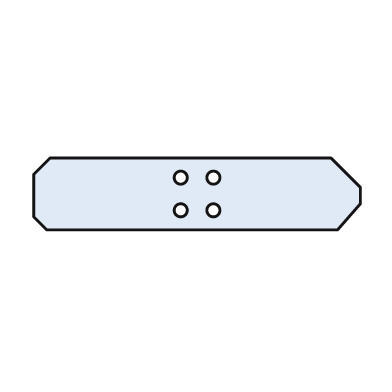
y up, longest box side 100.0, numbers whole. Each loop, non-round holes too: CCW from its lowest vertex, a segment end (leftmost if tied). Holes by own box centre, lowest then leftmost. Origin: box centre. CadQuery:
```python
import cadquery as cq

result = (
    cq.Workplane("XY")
    .moveTo(-46.0, -11.0)
    .lineTo(43.0, -11.0)
    .lineTo(50.0, -3.0)
    .lineTo(50.0, 2.0)
    .lineTo(41.0, 11.0)
    .lineTo(-45.0, 11.0)
    .lineTo(-50.0, 6.0)
    .lineTo(-50.0, -7.0)
    .close()
    .moveTo(-5.0, -5.0)
    .circle(2.0)
    .moveTo(5.0, -5.0)
    .circle(2.0)
    .moveTo(-5.0, 5.0)
    .circle(2.0)
    .moveTo(5.0, 5.0)
    .circle(2.0)
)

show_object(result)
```